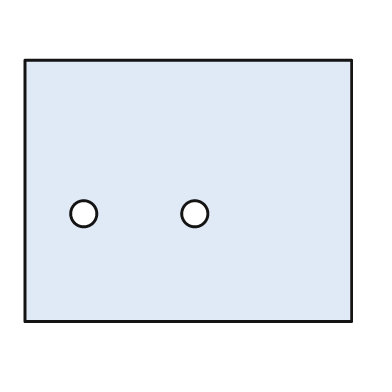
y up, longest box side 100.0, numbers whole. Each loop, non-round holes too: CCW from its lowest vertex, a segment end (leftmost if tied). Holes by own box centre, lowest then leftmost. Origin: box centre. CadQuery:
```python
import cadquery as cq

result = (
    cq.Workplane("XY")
    .moveTo(-50.0, -40.0)
    .lineTo(50.0, -40.0)
    .lineTo(50.0, 40.0)
    .lineTo(-50.0, 40.0)
    .close()
    .moveTo(-32.0, -7.0)
    .circle(4.0)
    .moveTo(2.0, -7.0)
    .circle(4.0)
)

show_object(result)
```